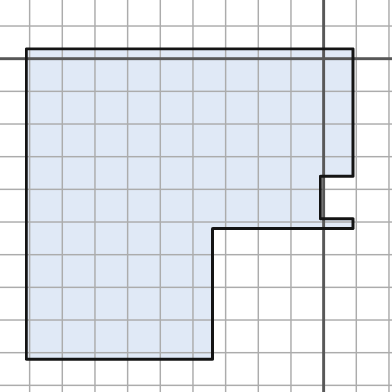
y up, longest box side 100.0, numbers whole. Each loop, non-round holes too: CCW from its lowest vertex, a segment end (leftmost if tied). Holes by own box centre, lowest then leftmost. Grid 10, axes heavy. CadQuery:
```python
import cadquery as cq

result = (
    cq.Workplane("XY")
    .moveTo(-91.0, -92.0)
    .lineTo(-34.0, -92.0)
    .lineTo(-34.0, -52.0)
    .lineTo(9.0, -52.0)
    .lineTo(9.0, -49.0)
    .lineTo(-1.0, -49.0)
    .lineTo(-1.0, -36.0)
    .lineTo(9.0, -36.0)
    .lineTo(9.0, 3.0)
    .lineTo(-91.0, 3.0)
    .close()
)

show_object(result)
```